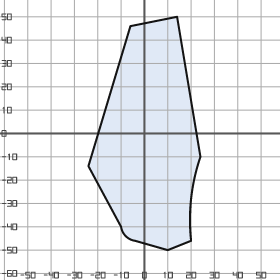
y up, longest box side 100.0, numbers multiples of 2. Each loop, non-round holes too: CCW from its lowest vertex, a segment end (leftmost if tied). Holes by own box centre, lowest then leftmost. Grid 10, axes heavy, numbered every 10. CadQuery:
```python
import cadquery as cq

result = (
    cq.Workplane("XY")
    .moveTo(10.0, -50.0)
    .lineTo(20.0, -46.0)
    .threePointArc((20.0, -28.0), (24.0, -10.0))
    .lineTo(14.0, 50.0)
    .lineTo(-6.0, 46.0)
    .lineTo(-24.0, -14.0)
    .lineTo(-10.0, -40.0)
    .threePointArc((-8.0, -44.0), (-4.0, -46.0))
    .close()
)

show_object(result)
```